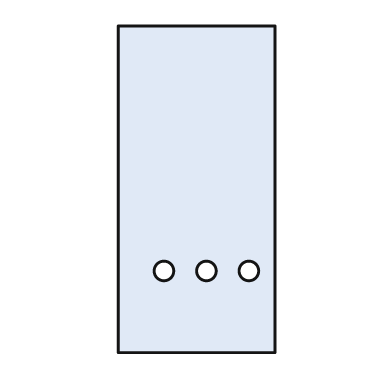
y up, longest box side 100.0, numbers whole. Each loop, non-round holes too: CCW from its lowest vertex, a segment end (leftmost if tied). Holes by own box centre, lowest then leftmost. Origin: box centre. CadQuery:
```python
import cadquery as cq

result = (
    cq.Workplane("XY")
    .moveTo(-24.0, -50.0)
    .lineTo(24.0, -50.0)
    .lineTo(24.0, 50.0)
    .lineTo(-24.0, 50.0)
    .close()
    .moveTo(-10.0, -25.0)
    .circle(3.0)
    .moveTo(3.0, -25.0)
    .circle(3.0)
    .moveTo(16.0, -25.0)
    .circle(3.0)
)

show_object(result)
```